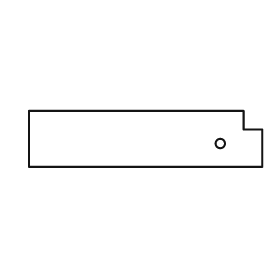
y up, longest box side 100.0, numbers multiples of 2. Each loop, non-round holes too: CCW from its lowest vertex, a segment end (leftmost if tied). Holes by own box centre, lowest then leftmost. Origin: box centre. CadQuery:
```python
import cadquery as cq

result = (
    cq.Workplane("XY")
    .moveTo(-50.0, -12.0)
    .lineTo(50.0, -12.0)
    .lineTo(50.0, 4.0)
    .lineTo(42.0, 4.0)
    .lineTo(42.0, 12.0)
    .lineTo(-50.0, 12.0)
    .close()
    .moveTo(32.0, -2.0)
    .circle(2.0)
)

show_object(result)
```